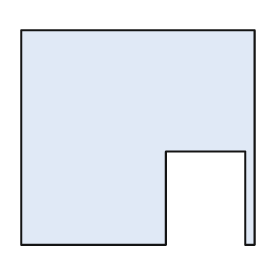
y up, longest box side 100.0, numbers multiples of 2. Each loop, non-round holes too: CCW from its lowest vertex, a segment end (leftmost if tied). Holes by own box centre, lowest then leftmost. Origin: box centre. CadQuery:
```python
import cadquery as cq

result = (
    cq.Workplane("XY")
    .moveTo(-50.0, -46.0)
    .lineTo(12.0, -46.0)
    .lineTo(12.0, -6.0)
    .lineTo(46.0, -6.0)
    .lineTo(46.0, -46.0)
    .lineTo(50.0, -46.0)
    .lineTo(50.0, 46.0)
    .lineTo(-50.0, 46.0)
    .close()
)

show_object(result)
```